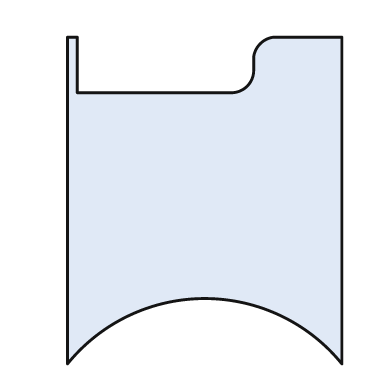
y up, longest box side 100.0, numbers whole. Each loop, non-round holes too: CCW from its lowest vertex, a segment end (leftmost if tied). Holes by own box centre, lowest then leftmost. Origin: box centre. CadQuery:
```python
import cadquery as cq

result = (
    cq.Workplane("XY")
    .moveTo(-42.0, -50.0)
    .threePointArc((0.0, -30.0), (42.0, -50.0))
    .lineTo(42.0, 50.0)
    .lineTo(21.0, 50.0)
    .threePointArc((17.0, 48.0), (15.0, 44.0))
    .lineTo(15.0, 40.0)
    .threePointArc((13.0, 35.0), (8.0, 33.0))
    .lineTo(-39.0, 33.0)
    .lineTo(-39.0, 50.0)
    .lineTo(-42.0, 50.0)
    .close()
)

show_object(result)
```